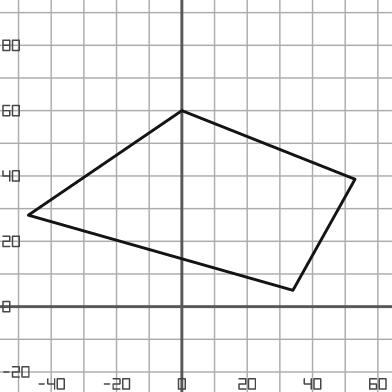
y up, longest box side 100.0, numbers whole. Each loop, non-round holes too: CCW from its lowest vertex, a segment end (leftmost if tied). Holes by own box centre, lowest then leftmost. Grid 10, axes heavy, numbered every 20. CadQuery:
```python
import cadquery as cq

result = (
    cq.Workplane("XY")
    .moveTo(34.0, 5.0)
    .lineTo(53.0, 39.0)
    .lineTo(0.0, 60.0)
    .lineTo(-47.0, 28.0)
    .close()
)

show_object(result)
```